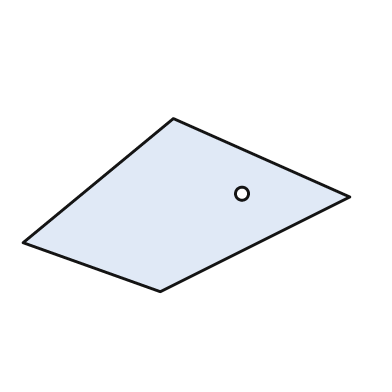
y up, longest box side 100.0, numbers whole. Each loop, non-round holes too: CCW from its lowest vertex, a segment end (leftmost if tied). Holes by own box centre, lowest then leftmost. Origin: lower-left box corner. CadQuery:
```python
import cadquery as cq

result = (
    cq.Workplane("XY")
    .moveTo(42.0, 0.0)
    .lineTo(100.0, 29.0)
    .lineTo(46.0, 53.0)
    .lineTo(0.0, 15.0)
    .close()
    .moveTo(67.0, 30.0)
    .circle(2.0)
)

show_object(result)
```